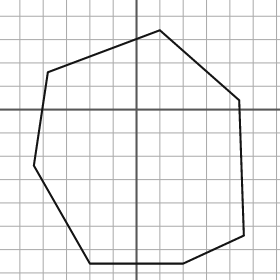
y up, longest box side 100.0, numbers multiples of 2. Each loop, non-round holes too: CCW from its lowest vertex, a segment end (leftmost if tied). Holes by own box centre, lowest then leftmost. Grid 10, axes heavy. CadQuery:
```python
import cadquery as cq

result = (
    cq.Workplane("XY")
    .moveTo(-20.0, -66.0)
    .lineTo(20.0, -66.0)
    .lineTo(46.0, -54.0)
    .lineTo(44.0, 4.0)
    .lineTo(10.0, 34.0)
    .lineTo(-38.0, 16.0)
    .lineTo(-44.0, -24.0)
    .close()
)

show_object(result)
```